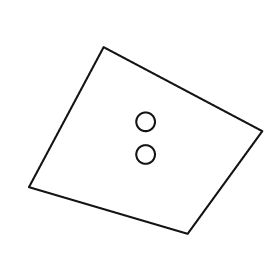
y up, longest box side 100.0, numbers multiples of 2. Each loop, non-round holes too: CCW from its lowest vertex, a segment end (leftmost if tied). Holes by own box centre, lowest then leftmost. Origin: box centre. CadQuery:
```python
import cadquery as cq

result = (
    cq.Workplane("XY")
    .moveTo(18.0, -40.0)
    .lineTo(50.0, 4.0)
    .lineTo(-18.0, 40.0)
    .lineTo(-50.0, -20.0)
    .close()
    .moveTo(0.0, -6.0)
    .circle(4.0)
    .moveTo(0.0, 8.0)
    .circle(4.0)
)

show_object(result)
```